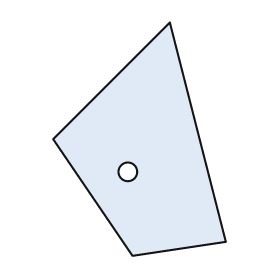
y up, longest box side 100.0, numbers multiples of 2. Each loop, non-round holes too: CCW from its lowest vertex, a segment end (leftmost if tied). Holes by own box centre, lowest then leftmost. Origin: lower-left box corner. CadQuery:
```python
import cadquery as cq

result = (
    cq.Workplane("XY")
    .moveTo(34.0, 0.0)
    .lineTo(74.0, 6.0)
    .lineTo(50.0, 100.0)
    .lineTo(0.0, 50.0)
    .close()
    .moveTo(32.0, 36.0)
    .circle(4.0)
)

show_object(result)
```